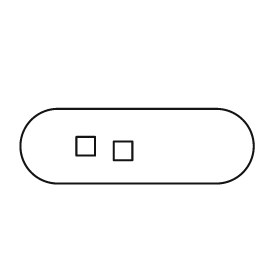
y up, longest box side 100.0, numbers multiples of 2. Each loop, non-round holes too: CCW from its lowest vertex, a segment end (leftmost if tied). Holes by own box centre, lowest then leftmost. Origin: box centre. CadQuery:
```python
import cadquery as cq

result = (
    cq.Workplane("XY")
    .moveTo(-34.0, -16.0)
    .lineTo(34.0, -16.0)
    .threePointArc((50.0, 0.0), (34.0, 16.0))
    .lineTo(-34.0, 16.0)
    .threePointArc((-50.0, 0.0), (-34.0, -16.0))
    .close()
    .moveTo(-10.0, -6.0)
    .lineTo(-2.0, -6.0)
    .lineTo(-2.0, 2.0)
    .lineTo(-10.0, 2.0)
    .close()
    .moveTo(-26.0, -4.0)
    .lineTo(-18.0, -4.0)
    .lineTo(-18.0, 4.0)
    .lineTo(-26.0, 4.0)
    .close()
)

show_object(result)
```